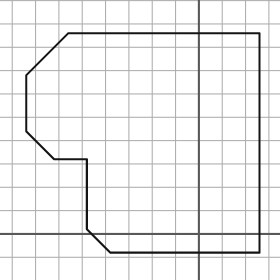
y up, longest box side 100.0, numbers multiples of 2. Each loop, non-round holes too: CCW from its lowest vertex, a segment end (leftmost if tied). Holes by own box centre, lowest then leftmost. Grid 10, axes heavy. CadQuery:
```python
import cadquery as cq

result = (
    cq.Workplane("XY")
    .moveTo(-38.0, -8.0)
    .lineTo(26.0, -8.0)
    .lineTo(26.0, 86.0)
    .lineTo(-56.0, 86.0)
    .lineTo(-74.0, 68.0)
    .lineTo(-74.0, 44.0)
    .lineTo(-62.0, 32.0)
    .lineTo(-48.0, 32.0)
    .lineTo(-48.0, 2.0)
    .close()
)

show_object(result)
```